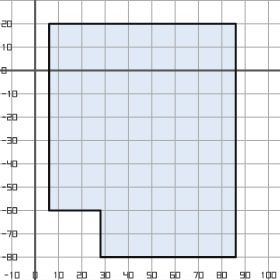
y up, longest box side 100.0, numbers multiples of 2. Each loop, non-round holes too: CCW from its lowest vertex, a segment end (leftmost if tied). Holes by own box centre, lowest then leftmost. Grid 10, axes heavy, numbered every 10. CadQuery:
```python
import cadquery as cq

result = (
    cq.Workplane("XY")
    .moveTo(28.0, -80.0)
    .lineTo(86.0, -80.0)
    .lineTo(86.0, 20.0)
    .lineTo(6.0, 20.0)
    .lineTo(6.0, -60.0)
    .lineTo(28.0, -60.0)
    .close()
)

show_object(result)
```